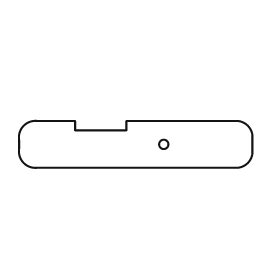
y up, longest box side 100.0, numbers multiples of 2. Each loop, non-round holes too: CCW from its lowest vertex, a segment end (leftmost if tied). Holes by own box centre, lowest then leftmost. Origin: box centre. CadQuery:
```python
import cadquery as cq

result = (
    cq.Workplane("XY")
    .moveTo(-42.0, -10.0)
    .lineTo(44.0, -10.0)
    .threePointArc((48.0, -8.0), (50.0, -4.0))
    .lineTo(50.0, 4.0)
    .threePointArc((48.0, 8.0), (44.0, 10.0))
    .lineTo(-4.0, 10.0)
    .lineTo(-4.0, 6.0)
    .lineTo(-26.0, 6.0)
    .lineTo(-26.0, 10.0)
    .lineTo(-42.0, 10.0)
    .threePointArc((-48.0, 8.0), (-50.0, 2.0))
    .lineTo(-50.0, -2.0)
    .threePointArc((-48.0, -8.0), (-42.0, -10.0))
    .close()
    .moveTo(12.0, 0.0)
    .circle(2.0)
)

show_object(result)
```